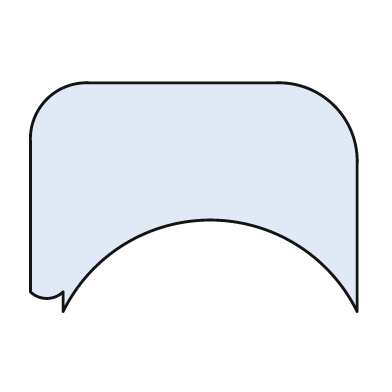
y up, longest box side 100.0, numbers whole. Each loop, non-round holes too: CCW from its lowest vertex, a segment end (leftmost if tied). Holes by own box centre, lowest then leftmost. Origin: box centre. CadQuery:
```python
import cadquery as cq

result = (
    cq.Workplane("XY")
    .moveTo(-40.0, -35.0)
    .threePointArc((5.0, -7.0), (50.0, -35.0))
    .lineTo(50.0, 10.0)
    .threePointArc((43.0, 28.0), (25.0, 35.0))
    .lineTo(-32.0, 35.0)
    .threePointArc((-45.0, 30.0), (-50.0, 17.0))
    .lineTo(-50.0, -29.0)
    .threePointArc((-45.0, -31.0), (-40.0, -29.0))
    .close()
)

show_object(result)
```